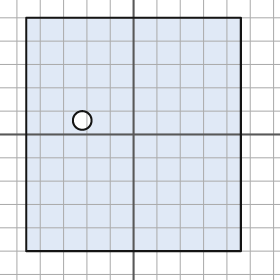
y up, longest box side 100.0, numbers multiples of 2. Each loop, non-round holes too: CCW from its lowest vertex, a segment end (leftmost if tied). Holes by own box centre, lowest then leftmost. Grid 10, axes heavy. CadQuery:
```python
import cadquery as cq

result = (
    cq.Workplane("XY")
    .moveTo(-46.0, -50.0)
    .lineTo(46.0, -50.0)
    .lineTo(46.0, 50.0)
    .lineTo(-46.0, 50.0)
    .close()
    .moveTo(-22.0, 6.0)
    .circle(4.0)
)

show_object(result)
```